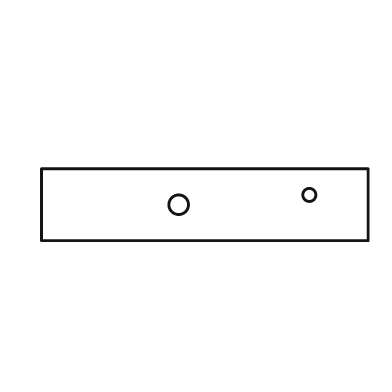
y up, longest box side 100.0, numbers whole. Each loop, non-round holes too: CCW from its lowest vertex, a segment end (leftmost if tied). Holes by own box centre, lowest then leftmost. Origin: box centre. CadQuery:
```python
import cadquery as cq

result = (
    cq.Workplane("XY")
    .moveTo(-50.0, -11.0)
    .lineTo(50.0, -11.0)
    .lineTo(50.0, 11.0)
    .lineTo(-50.0, 11.0)
    .close()
    .moveTo(-8.0, 0.0)
    .circle(3.0)
    .moveTo(32.0, 3.0)
    .circle(2.0)
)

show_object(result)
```